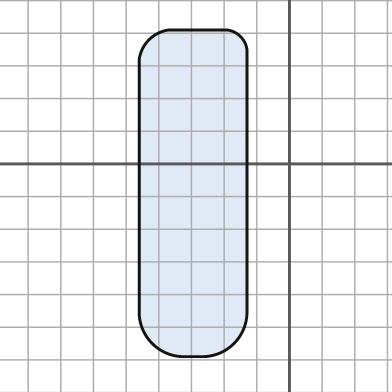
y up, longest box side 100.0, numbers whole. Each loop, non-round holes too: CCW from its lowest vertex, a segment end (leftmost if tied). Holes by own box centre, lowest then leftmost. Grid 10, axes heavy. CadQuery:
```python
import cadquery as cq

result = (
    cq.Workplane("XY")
    .moveTo(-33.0, -59.0)
    .lineTo(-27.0, -59.0)
    .threePointArc((-17.0, -55.0), (-13.0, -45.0))
    .lineTo(-13.0, 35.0)
    .threePointArc((-15.0, 39.0), (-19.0, 41.0))
    .lineTo(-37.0, 41.0)
    .threePointArc((-43.0, 38.0), (-46.0, 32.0))
    .lineTo(-46.0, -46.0)
    .threePointArc((-42.0, -55.0), (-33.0, -59.0))
    .close()
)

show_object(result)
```